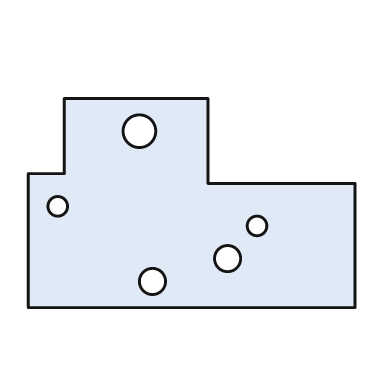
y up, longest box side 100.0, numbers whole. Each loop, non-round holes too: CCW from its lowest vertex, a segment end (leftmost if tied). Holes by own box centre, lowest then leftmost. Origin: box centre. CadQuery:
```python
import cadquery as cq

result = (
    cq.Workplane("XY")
    .moveTo(-50.0, -32.0)
    .lineTo(50.0, -32.0)
    .lineTo(50.0, 6.0)
    .lineTo(5.0, 6.0)
    .lineTo(5.0, 32.0)
    .lineTo(-39.0, 32.0)
    .lineTo(-39.0, 9.0)
    .lineTo(-50.0, 9.0)
    .close()
    .moveTo(-12.0, -24.0)
    .circle(4.0)
    .moveTo(11.0, -17.0)
    .circle(4.0)
    .moveTo(20.0, -7.0)
    .circle(3.0)
    .moveTo(-41.0, -1.0)
    .circle(3.0)
    .moveTo(-16.0, 22.0)
    .circle(5.0)
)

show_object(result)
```